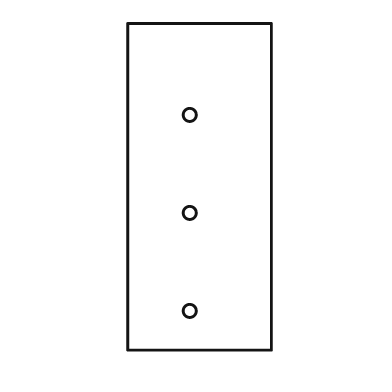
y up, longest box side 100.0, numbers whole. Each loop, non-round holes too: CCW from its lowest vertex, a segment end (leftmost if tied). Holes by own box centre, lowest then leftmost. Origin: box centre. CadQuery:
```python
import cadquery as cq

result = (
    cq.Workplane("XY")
    .moveTo(-22.0, -50.0)
    .lineTo(22.0, -50.0)
    .lineTo(22.0, 50.0)
    .lineTo(-22.0, 50.0)
    .close()
    .moveTo(-3.0, -38.0)
    .circle(2.0)
    .moveTo(-3.0, -8.0)
    .circle(2.0)
    .moveTo(-3.0, 22.0)
    .circle(2.0)
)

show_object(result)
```